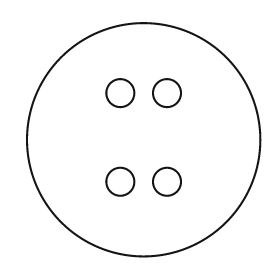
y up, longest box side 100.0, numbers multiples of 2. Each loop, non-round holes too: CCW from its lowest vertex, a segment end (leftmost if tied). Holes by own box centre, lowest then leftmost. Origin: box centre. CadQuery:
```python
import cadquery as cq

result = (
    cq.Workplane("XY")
    .moveTo(0.0, 0.0)
    .circle(50.0)
    .moveTo(-10.0, -18.0)
    .circle(6.0)
    .moveTo(10.0, -18.0)
    .circle(6.0)
    .moveTo(-10.0, 20.0)
    .circle(6.0)
    .moveTo(10.0, 20.0)
    .circle(6.0)
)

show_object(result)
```